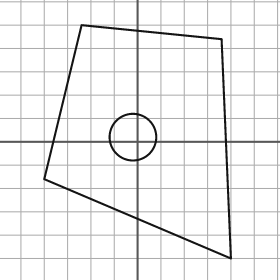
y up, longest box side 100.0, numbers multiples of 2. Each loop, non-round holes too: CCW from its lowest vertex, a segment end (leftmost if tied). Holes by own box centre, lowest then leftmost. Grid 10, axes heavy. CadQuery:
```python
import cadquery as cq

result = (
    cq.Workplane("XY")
    .moveTo(40.0, -50.0)
    .lineTo(36.0, 44.0)
    .lineTo(-24.0, 50.0)
    .lineTo(-40.0, -16.0)
    .close()
    .moveTo(-2.0, 2.0)
    .circle(10.0)
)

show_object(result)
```